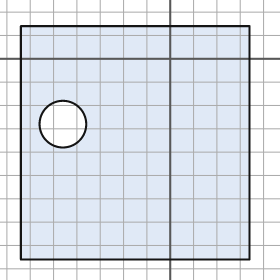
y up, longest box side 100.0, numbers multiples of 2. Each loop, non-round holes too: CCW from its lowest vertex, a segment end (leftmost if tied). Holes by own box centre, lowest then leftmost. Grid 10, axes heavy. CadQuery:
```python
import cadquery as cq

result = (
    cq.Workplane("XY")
    .moveTo(-64.0, -86.0)
    .lineTo(34.0, -86.0)
    .lineTo(34.0, 14.0)
    .lineTo(-64.0, 14.0)
    .close()
    .moveTo(-46.0, -28.0)
    .circle(10.0)
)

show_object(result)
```